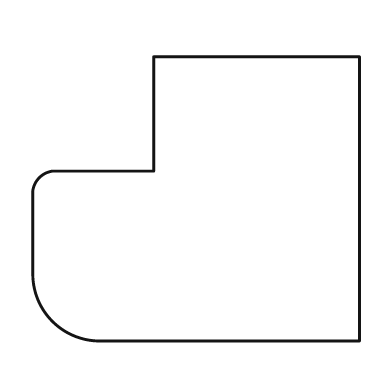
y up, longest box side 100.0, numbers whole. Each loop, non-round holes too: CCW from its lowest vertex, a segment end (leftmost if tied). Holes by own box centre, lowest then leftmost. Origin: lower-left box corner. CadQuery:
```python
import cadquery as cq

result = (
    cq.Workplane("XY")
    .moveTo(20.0, 0.0)
    .lineTo(100.0, 0.0)
    .lineTo(100.0, 87.0)
    .lineTo(37.0, 87.0)
    .lineTo(37.0, 52.0)
    .lineTo(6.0, 52.0)
    .threePointArc((2.0, 50.0), (0.0, 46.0))
    .lineTo(0.0, 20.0)
    .threePointArc((6.0, 6.0), (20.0, 0.0))
    .close()
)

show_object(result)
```